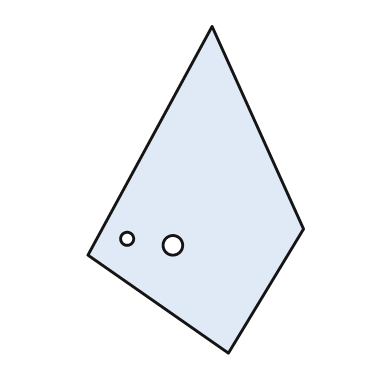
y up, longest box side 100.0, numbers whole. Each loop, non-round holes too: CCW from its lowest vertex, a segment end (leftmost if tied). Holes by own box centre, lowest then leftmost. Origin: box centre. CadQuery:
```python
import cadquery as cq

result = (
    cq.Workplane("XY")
    .moveTo(10.0, -50.0)
    .lineTo(33.0, -12.0)
    .lineTo(5.0, 50.0)
    .lineTo(-33.0, -20.0)
    .close()
    .moveTo(-7.0, -17.0)
    .circle(3.0)
    .moveTo(-21.0, -15.0)
    .circle(2.0)
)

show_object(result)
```